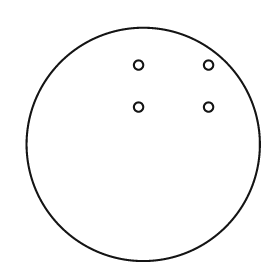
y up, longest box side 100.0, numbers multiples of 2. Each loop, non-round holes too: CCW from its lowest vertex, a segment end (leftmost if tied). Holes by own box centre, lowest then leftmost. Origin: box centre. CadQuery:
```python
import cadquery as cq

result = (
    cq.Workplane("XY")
    .moveTo(0.0, 0.0)
    .circle(50.0)
    .moveTo(-2.0, 16.0)
    .circle(2.0)
    .moveTo(28.0, 16.0)
    .circle(2.0)
    .moveTo(-2.0, 34.0)
    .circle(2.0)
    .moveTo(28.0, 34.0)
    .circle(2.0)
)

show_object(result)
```